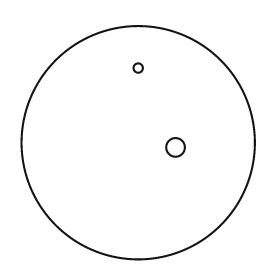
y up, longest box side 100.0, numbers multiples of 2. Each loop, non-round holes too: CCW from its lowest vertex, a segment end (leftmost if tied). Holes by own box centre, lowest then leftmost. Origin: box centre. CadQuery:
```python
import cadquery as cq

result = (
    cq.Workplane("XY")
    .moveTo(0.0, 0.0)
    .circle(50.0)
    .moveTo(16.0, -2.0)
    .circle(4.0)
    .moveTo(0.0, 32.0)
    .circle(2.0)
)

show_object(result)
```